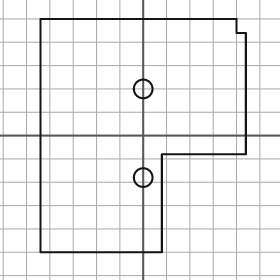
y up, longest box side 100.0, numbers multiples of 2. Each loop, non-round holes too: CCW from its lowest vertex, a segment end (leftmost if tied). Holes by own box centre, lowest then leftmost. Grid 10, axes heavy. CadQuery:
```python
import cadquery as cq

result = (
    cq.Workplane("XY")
    .moveTo(-44.0, -50.0)
    .lineTo(8.0, -50.0)
    .lineTo(8.0, -8.0)
    .lineTo(44.0, -8.0)
    .lineTo(44.0, 44.0)
    .lineTo(40.0, 44.0)
    .lineTo(40.0, 50.0)
    .lineTo(-44.0, 50.0)
    .close()
    .moveTo(0.0, -18.0)
    .circle(4.0)
    .moveTo(0.0, 20.0)
    .circle(4.0)
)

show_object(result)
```